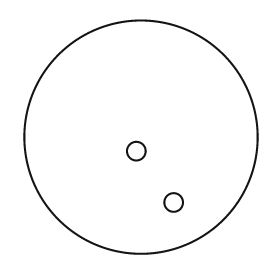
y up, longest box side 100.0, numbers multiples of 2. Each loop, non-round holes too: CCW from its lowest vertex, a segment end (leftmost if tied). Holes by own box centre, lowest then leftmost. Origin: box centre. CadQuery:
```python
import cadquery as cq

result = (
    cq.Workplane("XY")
    .moveTo(0.0, 0.0)
    .circle(50.0)
    .moveTo(14.0, -28.0)
    .circle(4.0)
    .moveTo(-2.0, -6.0)
    .circle(4.0)
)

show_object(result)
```